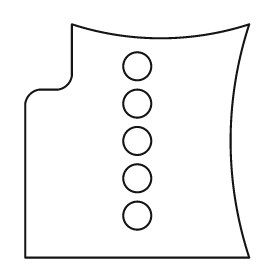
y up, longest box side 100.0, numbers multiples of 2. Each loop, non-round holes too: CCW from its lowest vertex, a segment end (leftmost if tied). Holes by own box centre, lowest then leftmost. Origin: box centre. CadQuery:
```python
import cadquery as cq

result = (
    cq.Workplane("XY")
    .moveTo(-48.0, -50.0)
    .lineTo(48.0, -50.0)
    .threePointArc((40.0, 0.0), (48.0, 50.0))
    .threePointArc((10.0, 44.0), (-28.0, 50.0))
    .lineTo(-28.0, 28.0)
    .threePointArc((-30.0, 24.0), (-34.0, 22.0))
    .lineTo(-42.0, 22.0)
    .threePointArc((-46.0, 20.0), (-48.0, 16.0))
    .close()
    .moveTo(0.0, -32.0)
    .circle(6.0)
    .moveTo(0.0, -16.0)
    .circle(6.0)
    .moveTo(0.0, 0.0)
    .circle(6.0)
    .moveTo(0.0, 16.0)
    .circle(6.0)
    .moveTo(0.0, 32.0)
    .circle(6.0)
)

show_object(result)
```